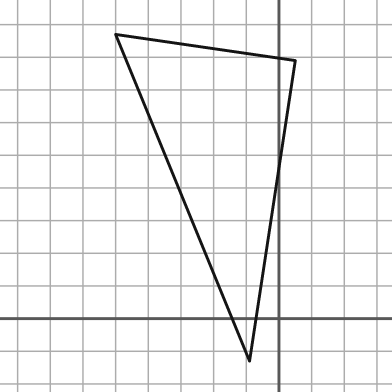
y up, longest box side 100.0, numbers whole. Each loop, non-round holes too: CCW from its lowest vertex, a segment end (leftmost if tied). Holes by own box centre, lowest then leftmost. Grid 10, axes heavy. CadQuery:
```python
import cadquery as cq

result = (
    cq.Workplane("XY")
    .moveTo(-9.0, -13.0)
    .lineTo(5.0, 79.0)
    .lineTo(-50.0, 87.0)
    .close()
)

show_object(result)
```